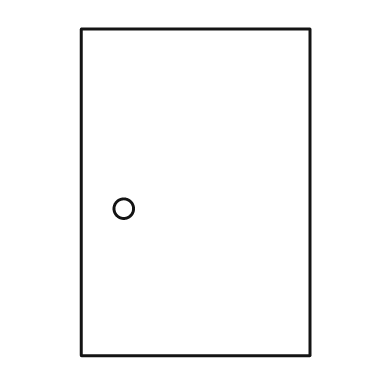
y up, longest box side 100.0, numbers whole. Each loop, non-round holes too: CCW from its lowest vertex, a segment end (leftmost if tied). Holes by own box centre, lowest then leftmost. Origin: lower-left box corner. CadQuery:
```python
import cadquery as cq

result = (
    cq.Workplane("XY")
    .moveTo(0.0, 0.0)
    .lineTo(70.0, 0.0)
    .lineTo(70.0, 100.0)
    .lineTo(0.0, 100.0)
    .close()
    .moveTo(13.0, 45.0)
    .circle(3.0)
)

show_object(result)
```